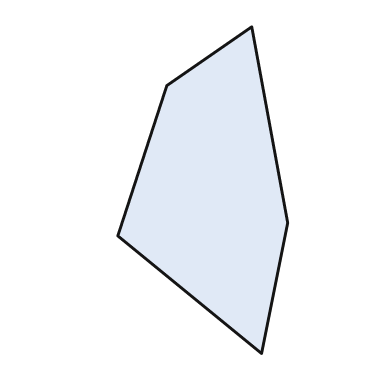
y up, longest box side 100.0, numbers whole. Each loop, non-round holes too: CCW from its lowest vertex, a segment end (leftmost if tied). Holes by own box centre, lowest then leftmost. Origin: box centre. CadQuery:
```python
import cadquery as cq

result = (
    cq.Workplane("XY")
    .moveTo(18.0, -50.0)
    .lineTo(26.0, -10.0)
    .lineTo(15.0, 50.0)
    .lineTo(-11.0, 32.0)
    .lineTo(-26.0, -14.0)
    .close()
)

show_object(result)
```